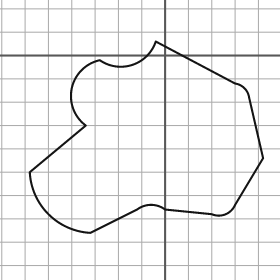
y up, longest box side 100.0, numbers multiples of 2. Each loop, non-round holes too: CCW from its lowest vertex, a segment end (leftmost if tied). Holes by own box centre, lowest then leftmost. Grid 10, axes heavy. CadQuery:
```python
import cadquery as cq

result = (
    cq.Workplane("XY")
    .moveTo(-32.0, -76.0)
    .lineTo(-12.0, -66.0)
    .threePointArc((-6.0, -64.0), (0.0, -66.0))
    .lineTo(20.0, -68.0)
    .threePointArc((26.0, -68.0), (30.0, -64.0))
    .lineTo(42.0, -44.0)
    .lineTo(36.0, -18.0)
    .threePointArc((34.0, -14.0), (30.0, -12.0))
    .lineTo(-4.0, 6.0)
    .threePointArc((-14.0, -4.0), (-28.0, -2.0))
    .threePointArc((-40.0, -14.0), (-34.0, -30.0))
    .lineTo(-58.0, -50.0)
    .threePointArc((-50.0, -68.0), (-32.0, -76.0))
    .close()
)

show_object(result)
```